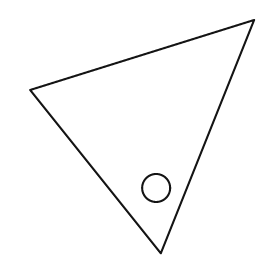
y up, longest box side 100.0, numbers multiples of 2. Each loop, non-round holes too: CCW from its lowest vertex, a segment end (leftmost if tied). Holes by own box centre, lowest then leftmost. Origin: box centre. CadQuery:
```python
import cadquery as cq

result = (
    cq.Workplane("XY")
    .moveTo(8.0, -50.0)
    .lineTo(48.0, 50.0)
    .lineTo(-48.0, 20.0)
    .close()
    .moveTo(6.0, -22.0)
    .circle(6.0)
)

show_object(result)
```